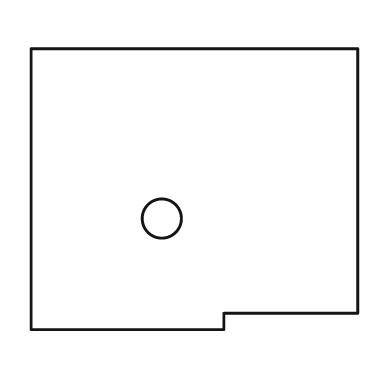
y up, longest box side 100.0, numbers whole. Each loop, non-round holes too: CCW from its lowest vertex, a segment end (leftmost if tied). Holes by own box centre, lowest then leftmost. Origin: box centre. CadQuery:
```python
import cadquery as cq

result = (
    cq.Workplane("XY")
    .moveTo(-50.0, -43.0)
    .lineTo(9.0, -43.0)
    .lineTo(9.0, -38.0)
    .lineTo(50.0, -38.0)
    .lineTo(50.0, 43.0)
    .lineTo(-50.0, 43.0)
    .close()
    .moveTo(-10.0, -9.0)
    .circle(6.0)
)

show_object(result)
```